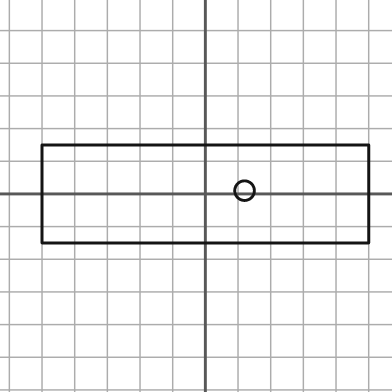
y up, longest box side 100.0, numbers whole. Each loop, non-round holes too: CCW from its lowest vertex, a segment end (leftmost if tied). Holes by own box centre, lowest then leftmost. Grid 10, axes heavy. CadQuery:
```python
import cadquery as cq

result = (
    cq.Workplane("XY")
    .moveTo(-50.0, -15.0)
    .lineTo(50.0, -15.0)
    .lineTo(50.0, 15.0)
    .lineTo(-50.0, 15.0)
    .close()
    .moveTo(12.0, 1.0)
    .circle(3.0)
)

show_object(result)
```